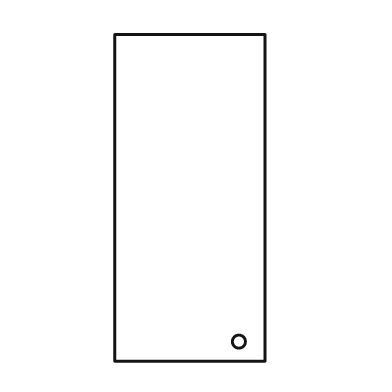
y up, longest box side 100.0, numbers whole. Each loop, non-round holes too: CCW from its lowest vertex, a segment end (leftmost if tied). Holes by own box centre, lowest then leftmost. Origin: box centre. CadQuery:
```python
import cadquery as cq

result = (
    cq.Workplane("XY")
    .moveTo(-23.0, -50.0)
    .lineTo(23.0, -50.0)
    .lineTo(23.0, 50.0)
    .lineTo(-23.0, 50.0)
    .close()
    .moveTo(15.0, -44.0)
    .circle(2.0)
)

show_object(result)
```